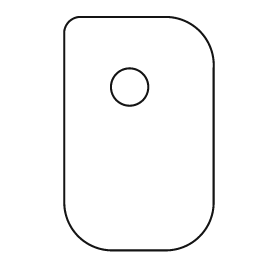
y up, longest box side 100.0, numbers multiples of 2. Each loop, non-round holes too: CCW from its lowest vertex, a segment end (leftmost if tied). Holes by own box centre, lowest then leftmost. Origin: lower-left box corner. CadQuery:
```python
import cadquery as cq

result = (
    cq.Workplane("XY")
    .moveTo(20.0, 0.0)
    .lineTo(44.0, 0.0)
    .threePointArc((58.0, 6.0), (64.0, 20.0))
    .lineTo(64.0, 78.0)
    .threePointArc((58.0, 94.0), (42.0, 100.0))
    .lineTo(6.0, 100.0)
    .threePointArc((2.0, 98.0), (0.0, 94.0))
    .lineTo(0.0, 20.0)
    .threePointArc((6.0, 6.0), (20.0, 0.0))
    .close()
    .moveTo(28.0, 70.0)
    .circle(8.0)
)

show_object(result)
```